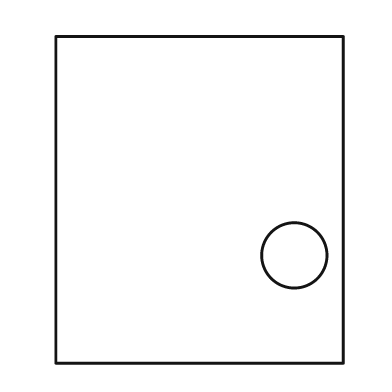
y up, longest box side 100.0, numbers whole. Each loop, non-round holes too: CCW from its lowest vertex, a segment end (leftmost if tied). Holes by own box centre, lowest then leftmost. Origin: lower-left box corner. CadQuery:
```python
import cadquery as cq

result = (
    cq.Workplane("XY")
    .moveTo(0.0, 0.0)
    .lineTo(88.0, 0.0)
    .lineTo(88.0, 100.0)
    .lineTo(0.0, 100.0)
    .close()
    .moveTo(73.0, 33.0)
    .circle(10.0)
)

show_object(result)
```